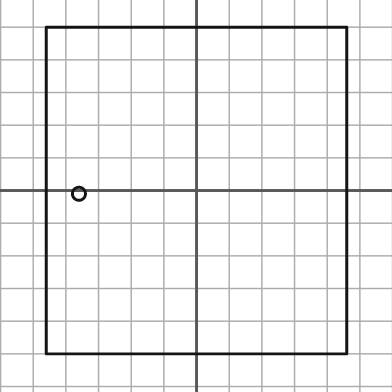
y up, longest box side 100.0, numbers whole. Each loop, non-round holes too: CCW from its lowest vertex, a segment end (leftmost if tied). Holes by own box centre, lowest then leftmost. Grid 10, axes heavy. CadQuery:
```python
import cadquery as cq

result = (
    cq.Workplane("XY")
    .moveTo(-46.0, -50.0)
    .lineTo(46.0, -50.0)
    .lineTo(46.0, 50.0)
    .lineTo(-46.0, 50.0)
    .close()
    .moveTo(-36.0, -1.0)
    .circle(2.0)
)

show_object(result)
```